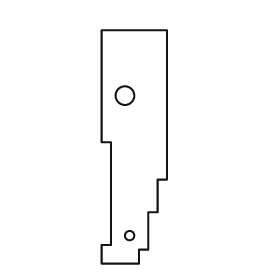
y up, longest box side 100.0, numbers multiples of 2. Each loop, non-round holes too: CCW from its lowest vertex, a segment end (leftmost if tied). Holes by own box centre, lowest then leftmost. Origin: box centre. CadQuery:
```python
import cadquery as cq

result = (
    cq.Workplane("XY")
    .moveTo(-14.0, -50.0)
    .lineTo(2.0, -50.0)
    .lineTo(2.0, -44.0)
    .lineTo(6.0, -44.0)
    .lineTo(6.0, -28.0)
    .lineTo(10.0, -28.0)
    .lineTo(10.0, -14.0)
    .lineTo(14.0, -14.0)
    .lineTo(14.0, 50.0)
    .lineTo(-14.0, 50.0)
    .lineTo(-14.0, 2.0)
    .lineTo(-10.0, 2.0)
    .lineTo(-10.0, -42.0)
    .lineTo(-14.0, -42.0)
    .close()
    .moveTo(-2.0, -38.0)
    .circle(2.0)
    .moveTo(-4.0, 22.0)
    .circle(4.0)
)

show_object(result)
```